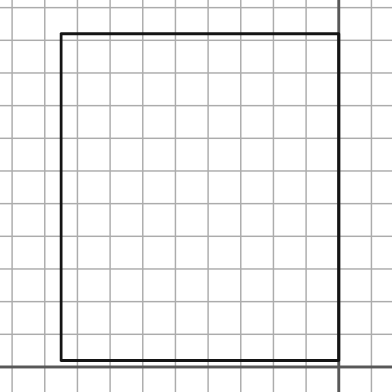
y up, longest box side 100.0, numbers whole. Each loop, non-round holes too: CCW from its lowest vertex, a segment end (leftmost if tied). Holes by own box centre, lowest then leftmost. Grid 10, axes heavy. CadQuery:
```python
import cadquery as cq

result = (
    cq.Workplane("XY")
    .moveTo(-85.0, 2.0)
    .lineTo(0.0, 2.0)
    .lineTo(0.0, 102.0)
    .lineTo(-85.0, 102.0)
    .close()
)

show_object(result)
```